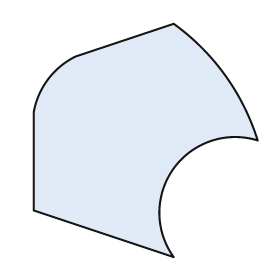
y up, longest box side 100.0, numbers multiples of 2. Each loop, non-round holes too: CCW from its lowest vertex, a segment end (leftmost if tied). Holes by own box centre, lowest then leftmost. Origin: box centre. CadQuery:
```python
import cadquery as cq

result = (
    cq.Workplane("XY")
    .moveTo(12.0, -50.0)
    .threePointArc((12.0, -12.0), (48.0, 0.0))
    .threePointArc((34.0, 28.0), (12.0, 50.0))
    .lineTo(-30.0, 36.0)
    .threePointArc((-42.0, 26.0), (-48.0, 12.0))
    .lineTo(-48.0, -30.0)
    .close()
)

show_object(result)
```